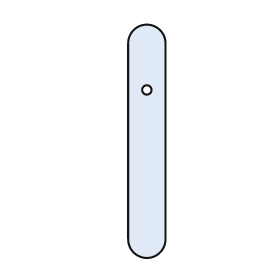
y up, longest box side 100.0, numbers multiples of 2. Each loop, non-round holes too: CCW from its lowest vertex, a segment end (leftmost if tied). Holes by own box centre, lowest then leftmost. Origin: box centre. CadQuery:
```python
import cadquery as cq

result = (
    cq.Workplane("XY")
    .moveTo(-8.0, -42.0)
    .threePointArc((0.0, -50.0), (8.0, -42.0))
    .lineTo(8.0, 42.0)
    .threePointArc((0.0, 50.0), (-8.0, 42.0))
    .close()
    .moveTo(0.0, 22.0)
    .circle(2.0)
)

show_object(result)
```